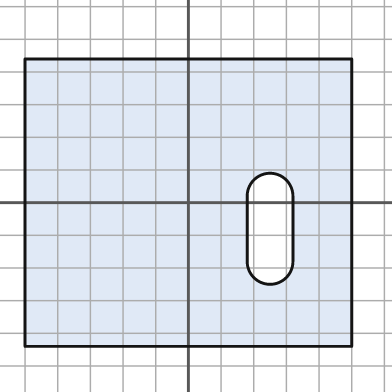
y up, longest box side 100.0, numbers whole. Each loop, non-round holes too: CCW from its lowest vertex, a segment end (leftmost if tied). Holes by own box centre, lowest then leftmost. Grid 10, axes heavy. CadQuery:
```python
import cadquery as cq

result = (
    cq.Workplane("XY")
    .moveTo(-50.0, -44.0)
    .lineTo(50.0, -44.0)
    .lineTo(50.0, 44.0)
    .lineTo(-50.0, 44.0)
    .close()
    .moveTo(18.0, -18.0)
    .threePointArc((25.0, -25.0), (32.0, -18.0))
    .lineTo(32.0, 2.0)
    .threePointArc((25.0, 9.0), (18.0, 2.0))
    .close()
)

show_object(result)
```